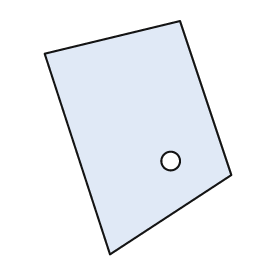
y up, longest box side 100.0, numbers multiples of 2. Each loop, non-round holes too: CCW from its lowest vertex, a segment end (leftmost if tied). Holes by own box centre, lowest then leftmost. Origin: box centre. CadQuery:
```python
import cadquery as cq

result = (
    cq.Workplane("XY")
    .moveTo(-12.0, -50.0)
    .lineTo(40.0, -16.0)
    .lineTo(18.0, 50.0)
    .lineTo(-40.0, 36.0)
    .close()
    .moveTo(14.0, -10.0)
    .circle(4.0)
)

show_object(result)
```